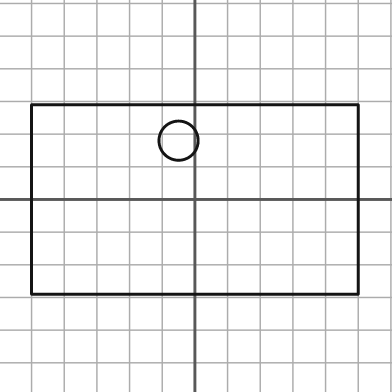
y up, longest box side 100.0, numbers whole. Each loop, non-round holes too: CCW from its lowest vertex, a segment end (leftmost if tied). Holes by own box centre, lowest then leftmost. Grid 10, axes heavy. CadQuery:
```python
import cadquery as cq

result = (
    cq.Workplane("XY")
    .moveTo(-50.0, -29.0)
    .lineTo(50.0, -29.0)
    .lineTo(50.0, 29.0)
    .lineTo(-50.0, 29.0)
    .close()
    .moveTo(-5.0, 18.0)
    .circle(6.0)
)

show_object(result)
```